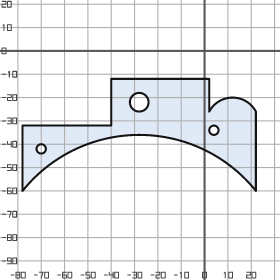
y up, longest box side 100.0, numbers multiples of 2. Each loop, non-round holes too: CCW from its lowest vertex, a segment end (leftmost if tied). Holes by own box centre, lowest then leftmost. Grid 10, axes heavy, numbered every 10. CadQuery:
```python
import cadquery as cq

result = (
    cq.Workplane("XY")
    .moveTo(-78.0, -60.0)
    .threePointArc((-28.0, -36.0), (22.0, -60.0))
    .lineTo(22.0, -26.0)
    .threePointArc((12.0, -20.0), (2.0, -26.0))
    .lineTo(2.0, -12.0)
    .lineTo(-40.0, -12.0)
    .lineTo(-40.0, -32.0)
    .lineTo(-78.0, -32.0)
    .close()
    .moveTo(-70.0, -42.0)
    .circle(2.0)
    .moveTo(4.0, -34.0)
    .circle(2.0)
    .moveTo(-28.0, -22.0)
    .circle(4.0)
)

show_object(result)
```